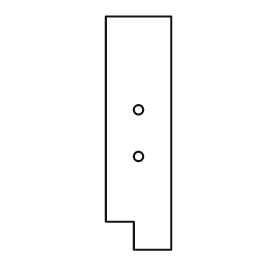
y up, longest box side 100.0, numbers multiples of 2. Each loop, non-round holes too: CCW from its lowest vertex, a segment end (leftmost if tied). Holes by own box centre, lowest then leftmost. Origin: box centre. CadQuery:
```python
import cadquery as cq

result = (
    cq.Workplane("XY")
    .moveTo(-2.0, -50.0)
    .lineTo(14.0, -50.0)
    .lineTo(14.0, 50.0)
    .lineTo(-14.0, 50.0)
    .lineTo(-14.0, -38.0)
    .lineTo(-2.0, -38.0)
    .close()
    .moveTo(0.0, -10.0)
    .circle(2.0)
    .moveTo(0.0, 10.0)
    .circle(2.0)
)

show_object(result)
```